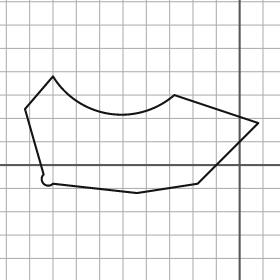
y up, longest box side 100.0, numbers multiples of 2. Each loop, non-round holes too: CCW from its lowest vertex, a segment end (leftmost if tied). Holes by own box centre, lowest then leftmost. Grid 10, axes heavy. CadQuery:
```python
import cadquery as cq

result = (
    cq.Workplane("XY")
    .moveTo(-44.0, -12.0)
    .lineTo(-18.0, -8.0)
    .lineTo(8.0, 18.0)
    .lineTo(-28.0, 30.0)
    .threePointArc((-56.0, 22.0), (-80.0, 38.0))
    .lineTo(-92.0, 24.0)
    .lineTo(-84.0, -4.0)
    .threePointArc((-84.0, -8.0), (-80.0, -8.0))
    .close()
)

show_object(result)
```